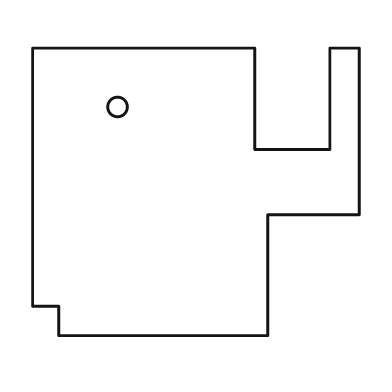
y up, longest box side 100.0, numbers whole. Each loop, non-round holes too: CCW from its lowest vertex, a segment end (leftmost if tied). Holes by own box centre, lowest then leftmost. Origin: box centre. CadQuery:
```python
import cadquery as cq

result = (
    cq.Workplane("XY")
    .moveTo(-42.0, -44.0)
    .lineTo(22.0, -44.0)
    .lineTo(22.0, -7.0)
    .lineTo(50.0, -7.0)
    .lineTo(50.0, 44.0)
    .lineTo(41.0, 44.0)
    .lineTo(41.0, 13.0)
    .lineTo(18.0, 13.0)
    .lineTo(18.0, 44.0)
    .lineTo(-50.0, 44.0)
    .lineTo(-50.0, -35.0)
    .lineTo(-42.0, -35.0)
    .close()
    .moveTo(-24.0, 26.0)
    .circle(3.0)
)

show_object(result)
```